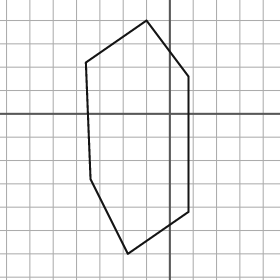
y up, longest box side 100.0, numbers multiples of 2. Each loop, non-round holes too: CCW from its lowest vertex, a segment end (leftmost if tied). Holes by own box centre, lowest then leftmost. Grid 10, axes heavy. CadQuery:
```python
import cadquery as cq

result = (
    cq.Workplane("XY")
    .moveTo(-18.0, -60.0)
    .lineTo(8.0, -42.0)
    .lineTo(8.0, 16.0)
    .lineTo(-10.0, 40.0)
    .lineTo(-36.0, 22.0)
    .lineTo(-34.0, -28.0)
    .close()
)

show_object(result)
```